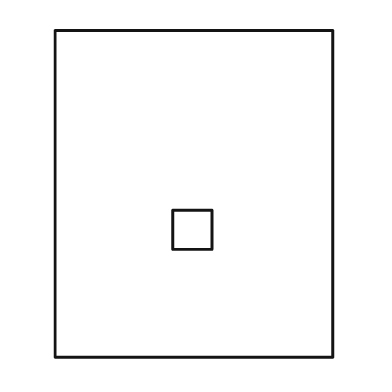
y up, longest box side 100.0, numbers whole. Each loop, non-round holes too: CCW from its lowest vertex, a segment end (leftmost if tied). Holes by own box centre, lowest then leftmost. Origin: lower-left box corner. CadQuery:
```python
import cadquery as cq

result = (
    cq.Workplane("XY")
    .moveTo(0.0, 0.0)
    .lineTo(85.0, 0.0)
    .lineTo(85.0, 100.0)
    .lineTo(0.0, 100.0)
    .close()
    .moveTo(36.0, 33.0)
    .lineTo(48.0, 33.0)
    .lineTo(48.0, 45.0)
    .lineTo(36.0, 45.0)
    .close()
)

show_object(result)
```